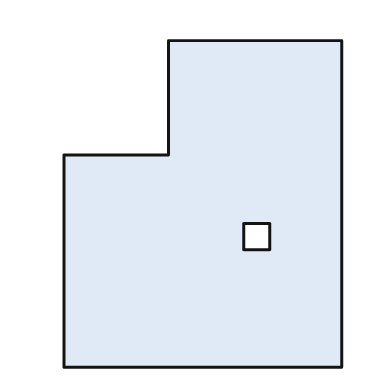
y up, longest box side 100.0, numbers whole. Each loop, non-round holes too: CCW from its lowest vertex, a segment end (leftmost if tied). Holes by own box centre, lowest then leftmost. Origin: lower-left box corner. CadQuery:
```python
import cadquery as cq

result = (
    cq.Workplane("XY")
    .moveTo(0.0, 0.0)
    .lineTo(85.0, 0.0)
    .lineTo(85.0, 100.0)
    .lineTo(32.0, 100.0)
    .lineTo(32.0, 65.0)
    .lineTo(0.0, 65.0)
    .close()
    .moveTo(55.0, 36.0)
    .lineTo(63.0, 36.0)
    .lineTo(63.0, 44.0)
    .lineTo(55.0, 44.0)
    .close()
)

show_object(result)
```